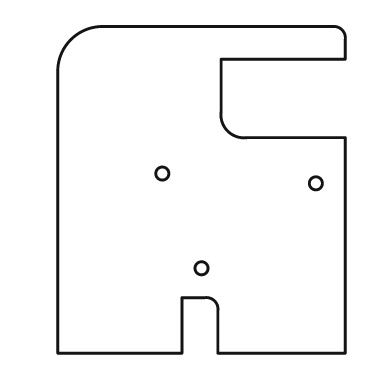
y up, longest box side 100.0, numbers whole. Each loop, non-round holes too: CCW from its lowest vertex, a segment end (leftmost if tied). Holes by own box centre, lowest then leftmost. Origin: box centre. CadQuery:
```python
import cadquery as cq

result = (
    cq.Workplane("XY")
    .moveTo(-44.0, -50.0)
    .lineTo(-6.0, -50.0)
    .lineTo(-6.0, -33.0)
    .lineTo(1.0, -33.0)
    .threePointArc((4.0, -34.0), (5.0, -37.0))
    .lineTo(5.0, -50.0)
    .lineTo(44.0, -50.0)
    .lineTo(44.0, 16.0)
    .lineTo(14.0, 16.0)
    .threePointArc((8.0, 18.0), (6.0, 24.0))
    .lineTo(6.0, 40.0)
    .lineTo(44.0, 40.0)
    .lineTo(44.0, 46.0)
    .threePointArc((43.0, 49.0), (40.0, 50.0))
    .lineTo(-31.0, 50.0)
    .threePointArc((-40.0, 46.0), (-44.0, 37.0))
    .close()
    .moveTo(0.0, -24.0)
    .circle(2.0)
    .moveTo(35.0, 2.0)
    .circle(2.0)
    .moveTo(-12.0, 5.0)
    .circle(2.0)
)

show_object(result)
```